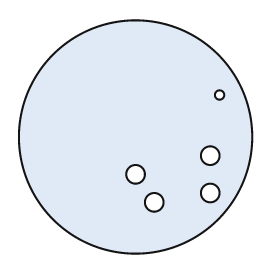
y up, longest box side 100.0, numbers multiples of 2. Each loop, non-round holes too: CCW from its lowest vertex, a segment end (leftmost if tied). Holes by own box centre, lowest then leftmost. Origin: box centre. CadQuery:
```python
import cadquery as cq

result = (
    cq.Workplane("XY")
    .moveTo(0.0, 0.0)
    .circle(50.0)
    .moveTo(8.0, -28.0)
    .circle(4.0)
    .moveTo(32.0, -24.0)
    .circle(4.0)
    .moveTo(0.0, -16.0)
    .circle(4.0)
    .moveTo(32.0, -8.0)
    .circle(4.0)
    .moveTo(36.0, 18.0)
    .circle(2.0)
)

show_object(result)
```